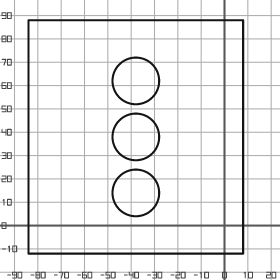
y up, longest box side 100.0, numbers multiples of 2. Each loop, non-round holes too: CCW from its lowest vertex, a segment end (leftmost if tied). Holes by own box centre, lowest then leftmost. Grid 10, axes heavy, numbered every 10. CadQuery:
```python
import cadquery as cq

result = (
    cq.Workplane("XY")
    .moveTo(-84.0, -12.0)
    .lineTo(8.0, -12.0)
    .lineTo(8.0, 88.0)
    .lineTo(-84.0, 88.0)
    .close()
    .moveTo(-38.0, 14.0)
    .circle(10.0)
    .moveTo(-38.0, 38.0)
    .circle(10.0)
    .moveTo(-38.0, 62.0)
    .circle(10.0)
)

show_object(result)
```